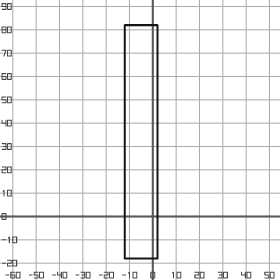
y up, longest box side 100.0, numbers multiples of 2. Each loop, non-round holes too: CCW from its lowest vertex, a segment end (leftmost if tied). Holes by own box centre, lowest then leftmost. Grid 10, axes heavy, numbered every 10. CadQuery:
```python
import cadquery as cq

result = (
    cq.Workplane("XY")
    .moveTo(-12.0, -18.0)
    .lineTo(2.0, -18.0)
    .lineTo(2.0, 82.0)
    .lineTo(-12.0, 82.0)
    .close()
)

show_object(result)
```